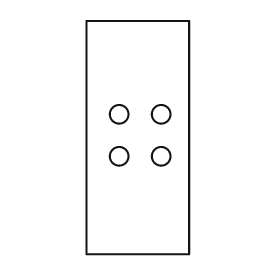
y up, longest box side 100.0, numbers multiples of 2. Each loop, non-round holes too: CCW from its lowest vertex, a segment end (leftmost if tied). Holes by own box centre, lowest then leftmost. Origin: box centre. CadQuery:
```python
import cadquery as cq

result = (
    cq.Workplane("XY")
    .moveTo(-22.0, -50.0)
    .lineTo(22.0, -50.0)
    .lineTo(22.0, 50.0)
    .lineTo(-22.0, 50.0)
    .close()
    .moveTo(-8.0, -8.0)
    .circle(4.0)
    .moveTo(10.0, -8.0)
    .circle(4.0)
    .moveTo(-8.0, 10.0)
    .circle(4.0)
    .moveTo(10.0, 10.0)
    .circle(4.0)
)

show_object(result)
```